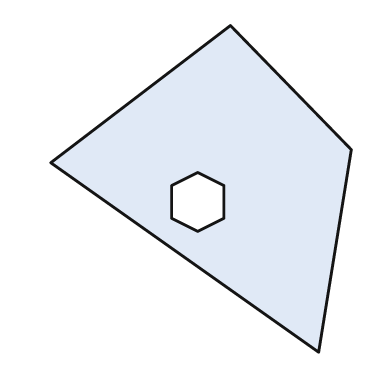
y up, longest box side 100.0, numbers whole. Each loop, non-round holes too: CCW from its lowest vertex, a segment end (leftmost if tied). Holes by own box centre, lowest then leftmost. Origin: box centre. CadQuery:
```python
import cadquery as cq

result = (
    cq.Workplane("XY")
    .moveTo(36.0, -50.0)
    .lineTo(46.0, 12.0)
    .lineTo(9.0, 50.0)
    .lineTo(-46.0, 8.0)
    .close()
    .moveTo(-1.0, -13.0)
    .lineTo(7.0, -9.0)
    .lineTo(7.0, 1.0)
    .lineTo(-1.0, 5.0)
    .lineTo(-9.0, 1.0)
    .lineTo(-9.0, -9.0)
    .close()
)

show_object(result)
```